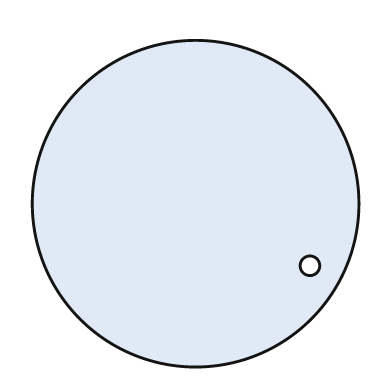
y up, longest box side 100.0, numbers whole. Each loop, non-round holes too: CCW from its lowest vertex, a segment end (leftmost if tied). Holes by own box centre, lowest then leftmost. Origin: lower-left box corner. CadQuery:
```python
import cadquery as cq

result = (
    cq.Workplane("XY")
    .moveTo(50.0, 50.0)
    .circle(50.0)
    .moveTo(85.0, 31.0)
    .circle(3.0)
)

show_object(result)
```